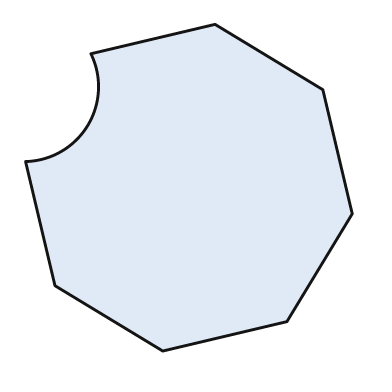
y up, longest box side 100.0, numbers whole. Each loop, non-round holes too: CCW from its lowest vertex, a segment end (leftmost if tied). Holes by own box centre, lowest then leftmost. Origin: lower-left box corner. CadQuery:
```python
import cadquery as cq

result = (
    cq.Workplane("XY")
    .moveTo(42.0, 0.0)
    .lineTo(80.0, 9.0)
    .lineTo(100.0, 42.0)
    .lineTo(91.0, 80.0)
    .lineTo(58.0, 100.0)
    .lineTo(20.0, 91.0)
    .threePointArc((19.0, 69.0), (0.0, 58.0))
    .lineTo(9.0, 20.0)
    .close()
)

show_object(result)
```